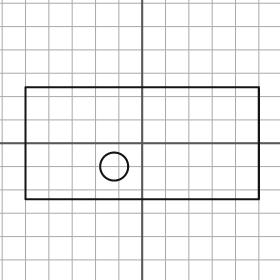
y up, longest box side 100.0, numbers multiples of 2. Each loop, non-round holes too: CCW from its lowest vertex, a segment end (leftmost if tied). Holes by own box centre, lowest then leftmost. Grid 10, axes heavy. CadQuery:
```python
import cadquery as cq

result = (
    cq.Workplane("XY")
    .moveTo(-50.0, -24.0)
    .lineTo(50.0, -24.0)
    .lineTo(50.0, 24.0)
    .lineTo(-50.0, 24.0)
    .close()
    .moveTo(-12.0, -10.0)
    .circle(6.0)
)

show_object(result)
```